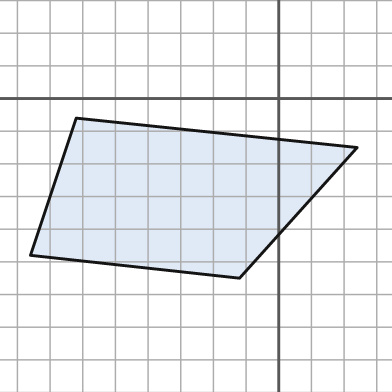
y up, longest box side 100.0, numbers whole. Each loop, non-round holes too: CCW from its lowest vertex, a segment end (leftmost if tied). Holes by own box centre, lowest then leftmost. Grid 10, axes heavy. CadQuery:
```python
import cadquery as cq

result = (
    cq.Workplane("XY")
    .moveTo(-12.0, -55.0)
    .lineTo(24.0, -15.0)
    .lineTo(-62.0, -6.0)
    .lineTo(-76.0, -48.0)
    .close()
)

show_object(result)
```